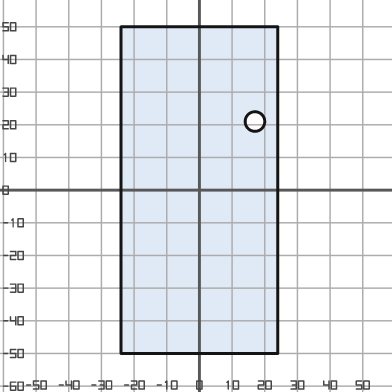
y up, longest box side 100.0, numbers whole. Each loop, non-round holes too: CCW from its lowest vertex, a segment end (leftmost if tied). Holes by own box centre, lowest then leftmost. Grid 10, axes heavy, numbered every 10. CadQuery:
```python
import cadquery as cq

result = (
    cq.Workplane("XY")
    .moveTo(-24.0, -50.0)
    .lineTo(24.0, -50.0)
    .lineTo(24.0, 50.0)
    .lineTo(-24.0, 50.0)
    .close()
    .moveTo(17.0, 21.0)
    .circle(3.0)
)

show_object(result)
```